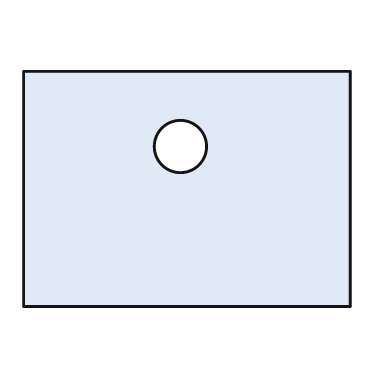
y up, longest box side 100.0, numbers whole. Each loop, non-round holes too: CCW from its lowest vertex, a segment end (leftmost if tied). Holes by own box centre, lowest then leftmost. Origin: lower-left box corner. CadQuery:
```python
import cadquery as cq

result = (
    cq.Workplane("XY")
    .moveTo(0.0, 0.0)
    .lineTo(100.0, 0.0)
    .lineTo(100.0, 72.0)
    .lineTo(0.0, 72.0)
    .close()
    .moveTo(48.0, 49.0)
    .circle(8.0)
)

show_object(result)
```